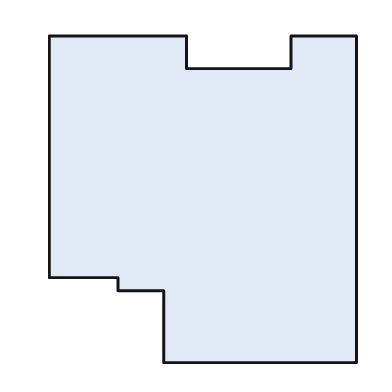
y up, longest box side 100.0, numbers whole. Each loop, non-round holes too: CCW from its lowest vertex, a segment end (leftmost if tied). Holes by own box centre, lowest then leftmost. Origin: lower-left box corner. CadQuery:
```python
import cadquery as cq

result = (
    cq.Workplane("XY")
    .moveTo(35.0, 0.0)
    .lineTo(94.0, 0.0)
    .lineTo(94.0, 100.0)
    .lineTo(74.0, 100.0)
    .lineTo(74.0, 90.0)
    .lineTo(42.0, 90.0)
    .lineTo(42.0, 100.0)
    .lineTo(0.0, 100.0)
    .lineTo(0.0, 26.0)
    .lineTo(21.0, 26.0)
    .lineTo(21.0, 22.0)
    .lineTo(35.0, 22.0)
    .close()
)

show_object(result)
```